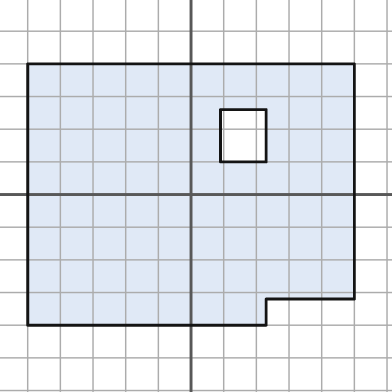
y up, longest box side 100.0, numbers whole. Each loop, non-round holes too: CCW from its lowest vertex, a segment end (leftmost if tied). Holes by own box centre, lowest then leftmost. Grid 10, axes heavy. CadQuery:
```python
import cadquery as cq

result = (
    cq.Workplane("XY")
    .moveTo(-50.0, -40.0)
    .lineTo(23.0, -40.0)
    .lineTo(23.0, -32.0)
    .lineTo(50.0, -32.0)
    .lineTo(50.0, 40.0)
    .lineTo(-50.0, 40.0)
    .close()
    .moveTo(9.0, 10.0)
    .lineTo(23.0, 10.0)
    .lineTo(23.0, 26.0)
    .lineTo(9.0, 26.0)
    .close()
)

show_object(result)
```